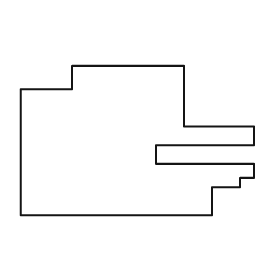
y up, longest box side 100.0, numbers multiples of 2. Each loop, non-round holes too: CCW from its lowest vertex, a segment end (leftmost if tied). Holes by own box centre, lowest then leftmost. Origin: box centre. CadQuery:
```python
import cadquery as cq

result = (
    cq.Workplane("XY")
    .moveTo(-50.0, -32.0)
    .lineTo(32.0, -32.0)
    .lineTo(32.0, -20.0)
    .lineTo(44.0, -20.0)
    .lineTo(44.0, -16.0)
    .lineTo(50.0, -16.0)
    .lineTo(50.0, -10.0)
    .lineTo(8.0, -10.0)
    .lineTo(8.0, -2.0)
    .lineTo(50.0, -2.0)
    .lineTo(50.0, 6.0)
    .lineTo(20.0, 6.0)
    .lineTo(20.0, 32.0)
    .lineTo(-28.0, 32.0)
    .lineTo(-28.0, 22.0)
    .lineTo(-50.0, 22.0)
    .close()
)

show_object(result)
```